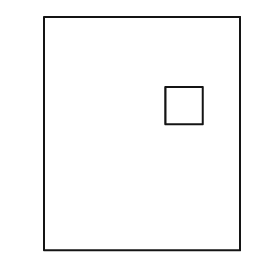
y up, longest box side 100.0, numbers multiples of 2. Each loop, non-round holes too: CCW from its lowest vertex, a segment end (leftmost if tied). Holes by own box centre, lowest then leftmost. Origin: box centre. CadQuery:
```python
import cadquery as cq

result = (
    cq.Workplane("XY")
    .moveTo(-42.0, -50.0)
    .lineTo(42.0, -50.0)
    .lineTo(42.0, 50.0)
    .lineTo(-42.0, 50.0)
    .close()
    .moveTo(10.0, 4.0)
    .lineTo(26.0, 4.0)
    .lineTo(26.0, 20.0)
    .lineTo(10.0, 20.0)
    .close()
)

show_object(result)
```